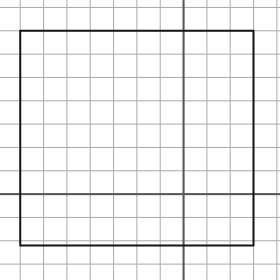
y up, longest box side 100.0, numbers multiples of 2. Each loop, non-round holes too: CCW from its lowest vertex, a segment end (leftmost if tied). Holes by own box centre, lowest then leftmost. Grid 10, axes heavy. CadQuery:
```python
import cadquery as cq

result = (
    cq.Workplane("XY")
    .moveTo(-70.0, -22.0)
    .lineTo(30.0, -22.0)
    .lineTo(30.0, 70.0)
    .lineTo(-70.0, 70.0)
    .close()
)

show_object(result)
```